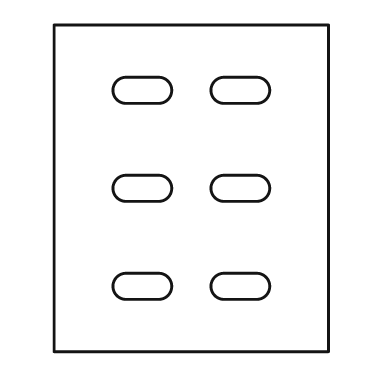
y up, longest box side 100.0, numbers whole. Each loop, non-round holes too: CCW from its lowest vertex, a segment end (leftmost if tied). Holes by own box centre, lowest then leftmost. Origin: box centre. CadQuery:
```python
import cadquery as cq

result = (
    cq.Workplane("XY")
    .moveTo(-42.0, -50.0)
    .lineTo(42.0, -50.0)
    .lineTo(42.0, 50.0)
    .lineTo(-42.0, 50.0)
    .close()
    .moveTo(-20.0, -34.0)
    .lineTo(-10.0, -34.0)
    .threePointArc((-6.0, -30.0), (-10.0, -26.0))
    .lineTo(-20.0, -26.0)
    .threePointArc((-24.0, -30.0), (-20.0, -34.0))
    .close()
    .moveTo(10.0, -34.0)
    .lineTo(20.0, -34.0)
    .threePointArc((24.0, -30.0), (20.0, -26.0))
    .lineTo(10.0, -26.0)
    .threePointArc((6.0, -30.0), (10.0, -34.0))
    .close()
    .moveTo(-20.0, -4.0)
    .lineTo(-10.0, -4.0)
    .threePointArc((-6.0, 0.0), (-10.0, 4.0))
    .lineTo(-20.0, 4.0)
    .threePointArc((-24.0, 0.0), (-20.0, -4.0))
    .close()
    .moveTo(10.0, -4.0)
    .lineTo(20.0, -4.0)
    .threePointArc((24.0, 0.0), (20.0, 4.0))
    .lineTo(10.0, 4.0)
    .threePointArc((6.0, 0.0), (10.0, -4.0))
    .close()
    .moveTo(-20.0, 26.0)
    .lineTo(-10.0, 26.0)
    .threePointArc((-6.0, 30.0), (-10.0, 34.0))
    .lineTo(-20.0, 34.0)
    .threePointArc((-24.0, 30.0), (-20.0, 26.0))
    .close()
    .moveTo(10.0, 26.0)
    .lineTo(20.0, 26.0)
    .threePointArc((24.0, 30.0), (20.0, 34.0))
    .lineTo(10.0, 34.0)
    .threePointArc((6.0, 30.0), (10.0, 26.0))
    .close()
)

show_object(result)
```